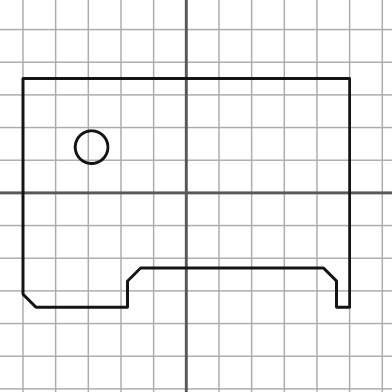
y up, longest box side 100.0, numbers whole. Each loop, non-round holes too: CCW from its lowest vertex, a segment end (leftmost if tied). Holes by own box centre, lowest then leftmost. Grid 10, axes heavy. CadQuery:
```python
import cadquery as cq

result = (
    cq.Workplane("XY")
    .moveTo(-46.0, -35.0)
    .lineTo(-18.0, -35.0)
    .lineTo(-18.0, -27.0)
    .lineTo(-14.0, -23.0)
    .lineTo(42.0, -23.0)
    .lineTo(46.0, -27.0)
    .lineTo(46.0, -35.0)
    .lineTo(50.0, -35.0)
    .lineTo(50.0, 35.0)
    .lineTo(-50.0, 35.0)
    .lineTo(-50.0, -31.0)
    .close()
    .moveTo(-29.0, 14.0)
    .circle(5.0)
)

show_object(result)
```